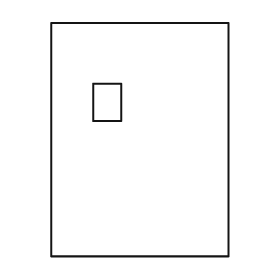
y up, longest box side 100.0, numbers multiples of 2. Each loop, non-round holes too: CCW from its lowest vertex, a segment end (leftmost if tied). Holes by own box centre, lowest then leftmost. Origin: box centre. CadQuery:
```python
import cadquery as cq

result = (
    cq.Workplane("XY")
    .moveTo(-38.0, -50.0)
    .lineTo(38.0, -50.0)
    .lineTo(38.0, 50.0)
    .lineTo(-38.0, 50.0)
    .close()
    .moveTo(-20.0, 8.0)
    .lineTo(-8.0, 8.0)
    .lineTo(-8.0, 24.0)
    .lineTo(-20.0, 24.0)
    .close()
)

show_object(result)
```